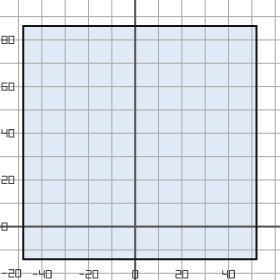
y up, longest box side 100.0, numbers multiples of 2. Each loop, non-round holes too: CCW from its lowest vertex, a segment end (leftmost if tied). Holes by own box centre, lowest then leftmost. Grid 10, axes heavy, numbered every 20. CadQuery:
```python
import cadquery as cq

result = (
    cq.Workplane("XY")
    .moveTo(-48.0, -14.0)
    .lineTo(52.0, -14.0)
    .lineTo(52.0, 86.0)
    .lineTo(-48.0, 86.0)
    .close()
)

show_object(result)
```